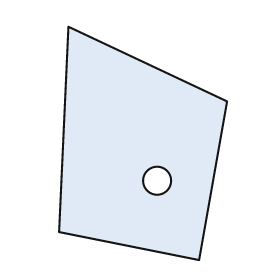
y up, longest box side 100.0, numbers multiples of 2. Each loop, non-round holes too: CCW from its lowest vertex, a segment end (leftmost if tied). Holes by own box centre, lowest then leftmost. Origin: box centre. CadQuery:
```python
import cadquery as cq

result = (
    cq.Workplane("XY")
    .moveTo(24.0, -50.0)
    .lineTo(36.0, 18.0)
    .lineTo(-32.0, 50.0)
    .lineTo(-36.0, -38.0)
    .close()
    .moveTo(6.0, -16.0)
    .circle(6.0)
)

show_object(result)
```